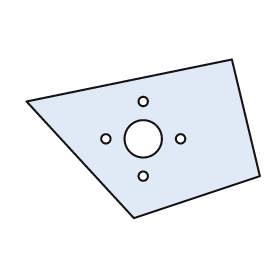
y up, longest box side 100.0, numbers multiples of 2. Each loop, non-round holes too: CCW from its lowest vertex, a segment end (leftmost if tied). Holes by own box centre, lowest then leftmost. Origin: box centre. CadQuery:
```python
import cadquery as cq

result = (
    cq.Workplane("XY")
    .moveTo(-4.0, -34.0)
    .lineTo(50.0, -16.0)
    .lineTo(38.0, 34.0)
    .lineTo(-50.0, 16.0)
    .close()
    .moveTo(0.0, -16.0)
    .circle(2.0)
    .moveTo(-16.0, 0.0)
    .circle(2.0)
    .moveTo(0.0, 0.0)
    .circle(8.0)
    .moveTo(16.0, 0.0)
    .circle(2.0)
    .moveTo(0.0, 16.0)
    .circle(2.0)
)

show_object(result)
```